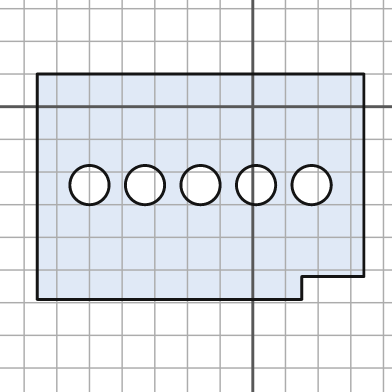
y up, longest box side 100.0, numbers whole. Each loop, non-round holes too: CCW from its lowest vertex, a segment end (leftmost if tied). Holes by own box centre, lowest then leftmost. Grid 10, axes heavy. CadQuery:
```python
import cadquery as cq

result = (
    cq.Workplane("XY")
    .moveTo(-66.0, -59.0)
    .lineTo(15.0, -59.0)
    .lineTo(15.0, -52.0)
    .lineTo(34.0, -52.0)
    .lineTo(34.0, 10.0)
    .lineTo(-66.0, 10.0)
    .close()
    .moveTo(-50.0, -24.0)
    .circle(6.0)
    .moveTo(-33.0, -24.0)
    .circle(6.0)
    .moveTo(-16.0, -24.0)
    .circle(6.0)
    .moveTo(1.0, -24.0)
    .circle(6.0)
    .moveTo(18.0, -24.0)
    .circle(6.0)
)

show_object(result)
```